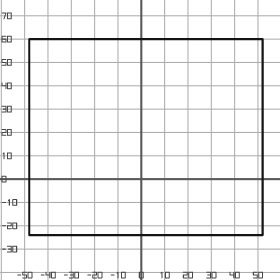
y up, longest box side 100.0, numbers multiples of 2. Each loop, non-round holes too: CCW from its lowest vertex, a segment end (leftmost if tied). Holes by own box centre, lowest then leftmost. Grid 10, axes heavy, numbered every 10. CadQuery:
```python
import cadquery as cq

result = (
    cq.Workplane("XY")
    .moveTo(-48.0, -24.0)
    .lineTo(52.0, -24.0)
    .lineTo(52.0, 60.0)
    .lineTo(-48.0, 60.0)
    .close()
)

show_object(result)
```